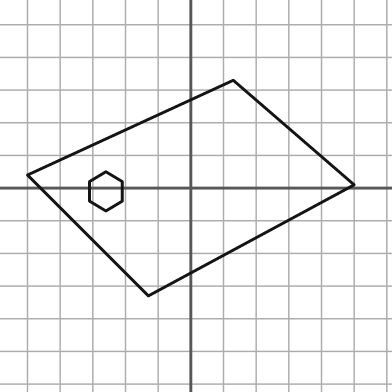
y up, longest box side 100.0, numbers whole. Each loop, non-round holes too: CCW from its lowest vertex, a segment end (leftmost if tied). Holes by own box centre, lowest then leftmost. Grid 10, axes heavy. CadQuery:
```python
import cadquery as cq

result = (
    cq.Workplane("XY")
    .moveTo(-13.0, -33.0)
    .lineTo(50.0, 1.0)
    .lineTo(13.0, 33.0)
    .lineTo(-50.0, 4.0)
    .close()
    .moveTo(-26.0, -7.0)
    .lineTo(-21.0, -4.0)
    .lineTo(-21.0, 2.0)
    .lineTo(-26.0, 5.0)
    .lineTo(-31.0, 2.0)
    .lineTo(-31.0, -4.0)
    .close()
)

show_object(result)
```